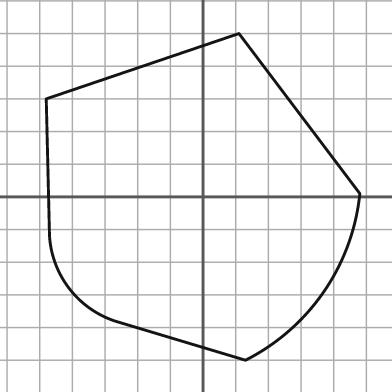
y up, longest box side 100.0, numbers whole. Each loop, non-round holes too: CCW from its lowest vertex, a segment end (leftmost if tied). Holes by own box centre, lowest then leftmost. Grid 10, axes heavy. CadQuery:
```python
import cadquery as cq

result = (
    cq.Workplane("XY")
    .moveTo(13.0, -50.0)
    .threePointArc((37.0, -29.0), (48.0, 1.0))
    .lineTo(11.0, 50.0)
    .lineTo(-48.0, 30.0)
    .lineTo(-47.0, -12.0)
    .threePointArc((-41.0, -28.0), (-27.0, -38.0))
    .close()
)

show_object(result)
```